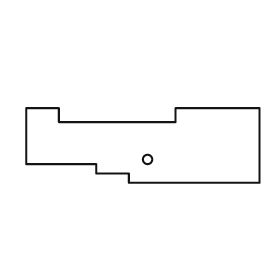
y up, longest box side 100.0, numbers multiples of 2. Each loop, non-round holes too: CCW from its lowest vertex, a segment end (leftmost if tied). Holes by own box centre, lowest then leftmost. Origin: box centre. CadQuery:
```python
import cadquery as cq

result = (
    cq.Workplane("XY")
    .moveTo(-6.0, -16.0)
    .lineTo(50.0, -16.0)
    .lineTo(50.0, 16.0)
    .lineTo(14.0, 16.0)
    .lineTo(14.0, 10.0)
    .lineTo(-36.0, 10.0)
    .lineTo(-36.0, 16.0)
    .lineTo(-50.0, 16.0)
    .lineTo(-50.0, -8.0)
    .lineTo(-20.0, -8.0)
    .lineTo(-20.0, -12.0)
    .lineTo(-6.0, -12.0)
    .close()
    .moveTo(2.0, -6.0)
    .circle(2.0)
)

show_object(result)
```